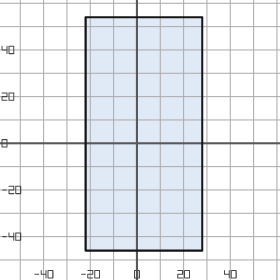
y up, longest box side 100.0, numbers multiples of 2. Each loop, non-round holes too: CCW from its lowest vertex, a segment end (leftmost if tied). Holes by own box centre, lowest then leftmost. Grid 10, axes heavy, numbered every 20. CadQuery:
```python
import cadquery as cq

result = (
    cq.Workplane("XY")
    .moveTo(-22.0, -46.0)
    .lineTo(28.0, -46.0)
    .lineTo(28.0, 54.0)
    .lineTo(-22.0, 54.0)
    .close()
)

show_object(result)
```